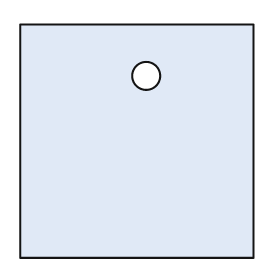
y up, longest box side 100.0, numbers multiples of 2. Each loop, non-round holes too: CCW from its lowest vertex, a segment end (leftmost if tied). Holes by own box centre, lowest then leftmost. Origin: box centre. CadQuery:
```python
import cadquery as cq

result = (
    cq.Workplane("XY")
    .moveTo(-50.0, -50.0)
    .lineTo(50.0, -50.0)
    .lineTo(50.0, 50.0)
    .lineTo(-50.0, 50.0)
    .close()
    .moveTo(4.0, 28.0)
    .circle(6.0)
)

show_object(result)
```